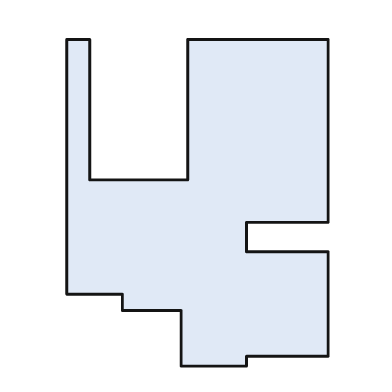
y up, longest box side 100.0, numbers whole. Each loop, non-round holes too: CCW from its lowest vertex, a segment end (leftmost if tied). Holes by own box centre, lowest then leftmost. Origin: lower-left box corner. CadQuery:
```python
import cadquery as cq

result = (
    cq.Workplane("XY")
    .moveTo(35.0, 0.0)
    .lineTo(55.0, 0.0)
    .lineTo(55.0, 3.0)
    .lineTo(80.0, 3.0)
    .lineTo(80.0, 35.0)
    .lineTo(55.0, 35.0)
    .lineTo(55.0, 44.0)
    .lineTo(80.0, 44.0)
    .lineTo(80.0, 100.0)
    .lineTo(37.0, 100.0)
    .lineTo(37.0, 57.0)
    .lineTo(7.0, 57.0)
    .lineTo(7.0, 100.0)
    .lineTo(0.0, 100.0)
    .lineTo(0.0, 22.0)
    .lineTo(17.0, 22.0)
    .lineTo(17.0, 17.0)
    .lineTo(35.0, 17.0)
    .close()
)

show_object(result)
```